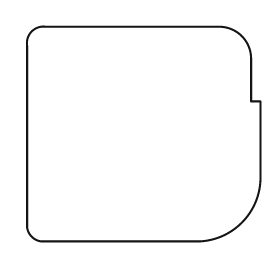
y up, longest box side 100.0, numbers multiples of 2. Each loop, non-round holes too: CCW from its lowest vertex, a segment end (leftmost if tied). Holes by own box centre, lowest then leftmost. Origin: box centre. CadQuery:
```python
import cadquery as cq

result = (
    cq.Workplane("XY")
    .moveTo(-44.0, -46.0)
    .lineTo(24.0, -46.0)
    .threePointArc((42.0, -38.0), (50.0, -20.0))
    .lineTo(50.0, 14.0)
    .lineTo(46.0, 14.0)
    .lineTo(46.0, 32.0)
    .threePointArc((42.0, 42.0), (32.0, 46.0))
    .lineTo(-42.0, 46.0)
    .threePointArc((-48.0, 44.0), (-50.0, 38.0))
    .lineTo(-50.0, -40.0)
    .threePointArc((-48.0, -44.0), (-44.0, -46.0))
    .close()
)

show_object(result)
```